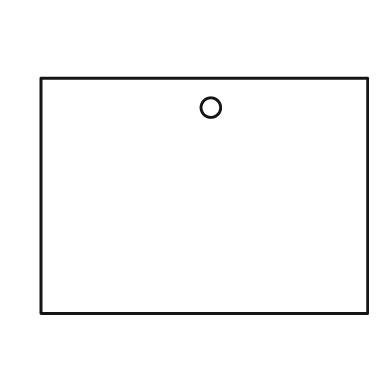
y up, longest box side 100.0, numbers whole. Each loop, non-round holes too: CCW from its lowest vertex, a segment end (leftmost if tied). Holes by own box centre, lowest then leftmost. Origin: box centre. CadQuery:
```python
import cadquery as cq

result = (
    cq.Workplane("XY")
    .moveTo(-50.0, -36.0)
    .lineTo(50.0, -36.0)
    .lineTo(50.0, 36.0)
    .lineTo(-50.0, 36.0)
    .close()
    .moveTo(2.0, 27.0)
    .circle(3.0)
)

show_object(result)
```